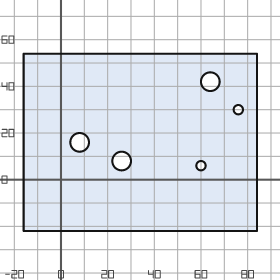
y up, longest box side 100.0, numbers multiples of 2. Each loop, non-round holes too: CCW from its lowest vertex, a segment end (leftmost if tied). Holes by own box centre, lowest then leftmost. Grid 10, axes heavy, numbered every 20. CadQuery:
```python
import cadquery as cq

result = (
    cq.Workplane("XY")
    .moveTo(-16.0, -22.0)
    .lineTo(84.0, -22.0)
    .lineTo(84.0, 54.0)
    .lineTo(-16.0, 54.0)
    .close()
    .moveTo(60.0, 6.0)
    .circle(2.0)
    .moveTo(26.0, 8.0)
    .circle(4.0)
    .moveTo(8.0, 16.0)
    .circle(4.0)
    .moveTo(76.0, 30.0)
    .circle(2.0)
    .moveTo(64.0, 42.0)
    .circle(4.0)
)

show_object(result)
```